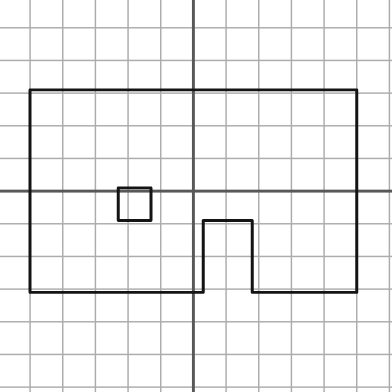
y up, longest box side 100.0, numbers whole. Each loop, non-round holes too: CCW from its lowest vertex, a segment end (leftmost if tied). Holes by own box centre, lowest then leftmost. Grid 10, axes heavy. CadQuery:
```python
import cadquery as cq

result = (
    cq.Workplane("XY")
    .moveTo(-50.0, -31.0)
    .lineTo(3.0, -31.0)
    .lineTo(3.0, -9.0)
    .lineTo(18.0, -9.0)
    .lineTo(18.0, -31.0)
    .lineTo(50.0, -31.0)
    .lineTo(50.0, 31.0)
    .lineTo(-50.0, 31.0)
    .close()
    .moveTo(-23.0, -9.0)
    .lineTo(-13.0, -9.0)
    .lineTo(-13.0, 1.0)
    .lineTo(-23.0, 1.0)
    .close()
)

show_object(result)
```